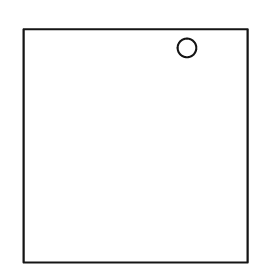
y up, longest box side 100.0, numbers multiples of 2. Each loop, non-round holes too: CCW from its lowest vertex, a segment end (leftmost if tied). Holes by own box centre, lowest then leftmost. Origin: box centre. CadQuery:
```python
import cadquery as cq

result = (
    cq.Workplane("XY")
    .moveTo(-48.0, -50.0)
    .lineTo(48.0, -50.0)
    .lineTo(48.0, 50.0)
    .lineTo(-48.0, 50.0)
    .close()
    .moveTo(22.0, 42.0)
    .circle(4.0)
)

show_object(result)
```